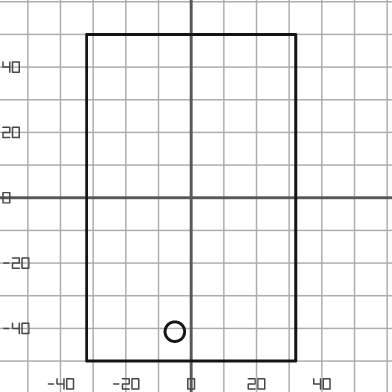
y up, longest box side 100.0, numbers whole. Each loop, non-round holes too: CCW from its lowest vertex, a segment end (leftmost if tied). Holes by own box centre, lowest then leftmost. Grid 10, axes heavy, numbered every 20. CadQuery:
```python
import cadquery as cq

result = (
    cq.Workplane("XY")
    .moveTo(-32.0, -50.0)
    .lineTo(32.0, -50.0)
    .lineTo(32.0, 50.0)
    .lineTo(-32.0, 50.0)
    .close()
    .moveTo(-5.0, -41.0)
    .circle(3.0)
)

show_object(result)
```